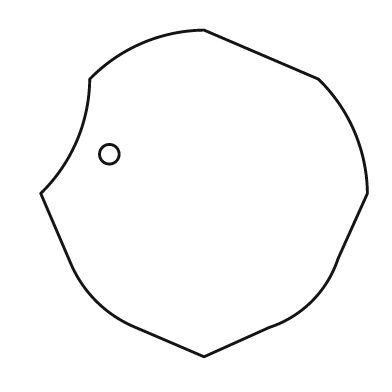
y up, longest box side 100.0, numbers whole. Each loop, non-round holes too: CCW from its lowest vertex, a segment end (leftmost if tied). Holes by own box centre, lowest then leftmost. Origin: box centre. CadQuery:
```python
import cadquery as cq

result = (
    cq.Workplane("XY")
    .moveTo(0.0, -50.0)
    .lineTo(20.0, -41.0)
    .threePointArc((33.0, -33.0), (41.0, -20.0))
    .lineTo(50.0, 0.0)
    .threePointArc((46.0, 19.0), (35.0, 35.0))
    .lineTo(0.0, 50.0)
    .threePointArc((-19.0, 46.0), (-35.0, 35.0))
    .threePointArc((-39.0, 16.0), (-50.0, 0.0))
    .lineTo(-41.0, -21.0)
    .threePointArc((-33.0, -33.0), (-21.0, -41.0))
    .close()
    .moveTo(-29.0, 12.0)
    .circle(3.0)
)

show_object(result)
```